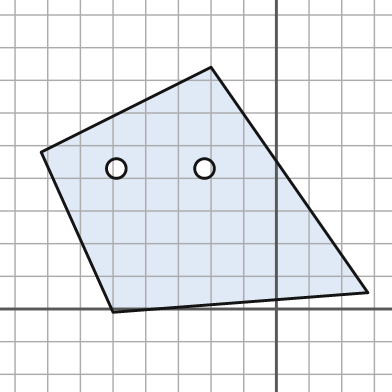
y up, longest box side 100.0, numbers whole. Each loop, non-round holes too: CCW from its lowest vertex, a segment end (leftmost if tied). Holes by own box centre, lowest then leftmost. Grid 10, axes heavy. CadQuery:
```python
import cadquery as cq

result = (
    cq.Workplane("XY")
    .moveTo(-50.0, -1.0)
    .lineTo(28.0, 5.0)
    .lineTo(-20.0, 74.0)
    .lineTo(-72.0, 48.0)
    .close()
    .moveTo(-49.0, 43.0)
    .circle(3.0)
    .moveTo(-22.0, 43.0)
    .circle(3.0)
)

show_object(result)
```